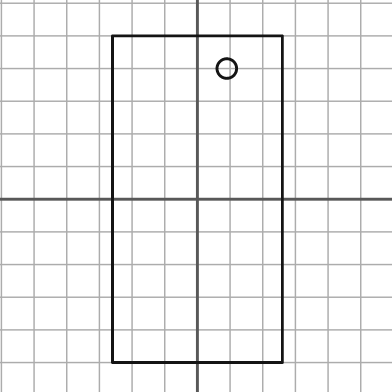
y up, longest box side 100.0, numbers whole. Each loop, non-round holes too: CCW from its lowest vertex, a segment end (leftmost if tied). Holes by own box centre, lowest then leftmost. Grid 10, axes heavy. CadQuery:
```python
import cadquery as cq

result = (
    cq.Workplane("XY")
    .moveTo(-26.0, -50.0)
    .lineTo(26.0, -50.0)
    .lineTo(26.0, 50.0)
    .lineTo(-26.0, 50.0)
    .close()
    .moveTo(9.0, 40.0)
    .circle(3.0)
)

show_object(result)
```